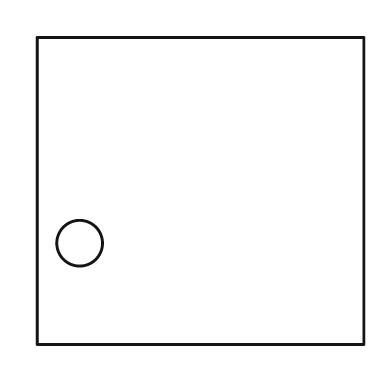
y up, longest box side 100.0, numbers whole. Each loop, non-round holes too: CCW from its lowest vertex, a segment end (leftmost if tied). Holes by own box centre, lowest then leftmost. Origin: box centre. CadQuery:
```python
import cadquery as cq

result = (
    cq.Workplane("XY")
    .moveTo(-50.0, -47.0)
    .lineTo(50.0, -47.0)
    .lineTo(50.0, 47.0)
    .lineTo(-50.0, 47.0)
    .close()
    .moveTo(-37.0, -16.0)
    .circle(7.0)
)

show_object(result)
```